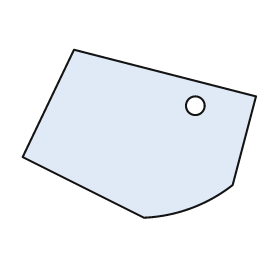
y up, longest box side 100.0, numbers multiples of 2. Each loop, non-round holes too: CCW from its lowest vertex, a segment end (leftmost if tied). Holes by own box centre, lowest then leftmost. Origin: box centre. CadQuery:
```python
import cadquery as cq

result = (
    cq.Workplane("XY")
    .moveTo(2.0, -36.0)
    .threePointArc((22.0, -32.0), (40.0, -22.0))
    .lineTo(50.0, 16.0)
    .lineTo(-28.0, 36.0)
    .lineTo(-50.0, -10.0)
    .close()
    .moveTo(24.0, 12.0)
    .circle(4.0)
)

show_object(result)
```